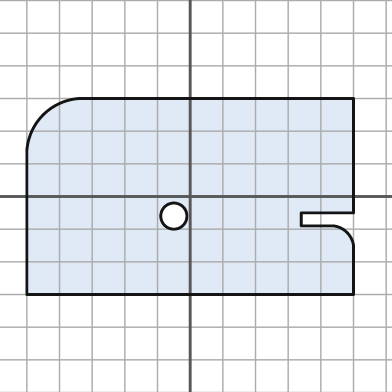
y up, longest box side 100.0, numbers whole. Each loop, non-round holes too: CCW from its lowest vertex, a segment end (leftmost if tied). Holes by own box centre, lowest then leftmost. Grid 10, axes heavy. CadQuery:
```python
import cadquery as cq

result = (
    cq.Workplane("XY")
    .moveTo(-50.0, -30.0)
    .lineTo(50.0, -30.0)
    .lineTo(50.0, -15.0)
    .threePointArc((48.0, -11.0), (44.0, -9.0))
    .lineTo(34.0, -9.0)
    .lineTo(34.0, -5.0)
    .lineTo(50.0, -5.0)
    .lineTo(50.0, 30.0)
    .lineTo(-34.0, 30.0)
    .threePointArc((-45.0, 25.0), (-50.0, 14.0))
    .close()
    .moveTo(-5.0, -6.0)
    .circle(4.0)
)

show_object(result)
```